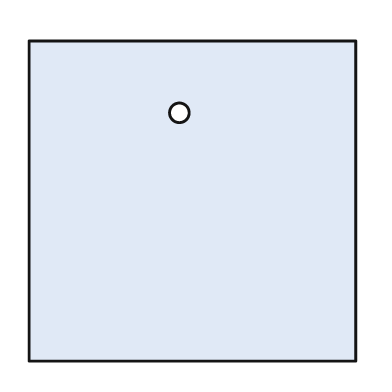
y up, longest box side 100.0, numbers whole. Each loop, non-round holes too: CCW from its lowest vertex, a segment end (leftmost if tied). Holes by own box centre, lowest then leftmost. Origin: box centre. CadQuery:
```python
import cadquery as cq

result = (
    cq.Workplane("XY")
    .moveTo(-50.0, -49.0)
    .lineTo(50.0, -49.0)
    .lineTo(50.0, 49.0)
    .lineTo(-50.0, 49.0)
    .close()
    .moveTo(-4.0, 27.0)
    .circle(3.0)
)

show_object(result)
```